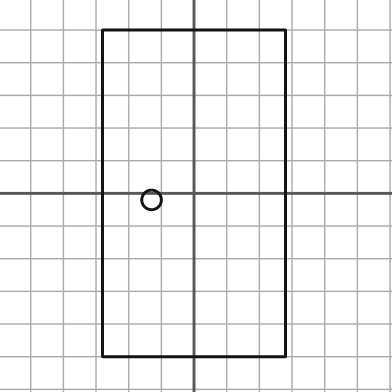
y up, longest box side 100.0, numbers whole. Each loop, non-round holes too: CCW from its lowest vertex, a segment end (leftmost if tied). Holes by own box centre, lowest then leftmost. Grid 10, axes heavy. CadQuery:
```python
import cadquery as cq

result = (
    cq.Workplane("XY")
    .moveTo(-28.0, -50.0)
    .lineTo(28.0, -50.0)
    .lineTo(28.0, 50.0)
    .lineTo(-28.0, 50.0)
    .close()
    .moveTo(-13.0, -2.0)
    .circle(3.0)
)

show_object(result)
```